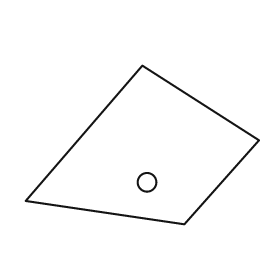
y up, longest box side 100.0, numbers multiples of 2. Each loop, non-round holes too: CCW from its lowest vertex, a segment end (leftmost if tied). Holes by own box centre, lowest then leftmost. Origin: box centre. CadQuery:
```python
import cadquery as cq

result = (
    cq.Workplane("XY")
    .moveTo(18.0, -34.0)
    .lineTo(50.0, 2.0)
    .lineTo(0.0, 34.0)
    .lineTo(-50.0, -24.0)
    .close()
    .moveTo(2.0, -16.0)
    .circle(4.0)
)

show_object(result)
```